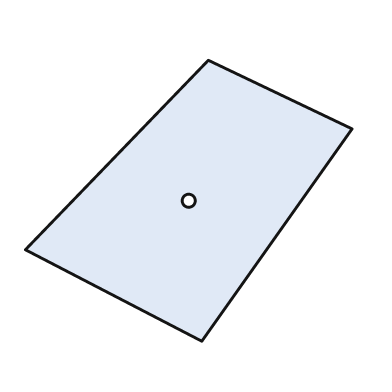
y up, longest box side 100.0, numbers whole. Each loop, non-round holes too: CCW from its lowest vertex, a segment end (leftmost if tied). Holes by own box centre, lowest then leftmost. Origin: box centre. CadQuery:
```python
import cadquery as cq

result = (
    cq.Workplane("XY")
    .moveTo(4.0, -43.0)
    .lineTo(50.0, 22.0)
    .lineTo(6.0, 43.0)
    .lineTo(-50.0, -15.0)
    .close()
    .moveTo(0.0, 0.0)
    .circle(2.0)
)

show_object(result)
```